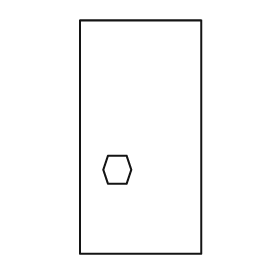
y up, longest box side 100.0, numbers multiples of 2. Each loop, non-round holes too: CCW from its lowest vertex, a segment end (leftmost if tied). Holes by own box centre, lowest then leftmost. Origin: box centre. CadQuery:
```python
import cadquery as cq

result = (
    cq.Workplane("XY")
    .moveTo(-26.0, -50.0)
    .lineTo(26.0, -50.0)
    .lineTo(26.0, 50.0)
    .lineTo(-26.0, 50.0)
    .close()
    .moveTo(-14.0, -20.0)
    .lineTo(-6.0, -20.0)
    .lineTo(-4.0, -14.0)
    .lineTo(-6.0, -8.0)
    .lineTo(-14.0, -8.0)
    .lineTo(-16.0, -14.0)
    .close()
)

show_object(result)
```